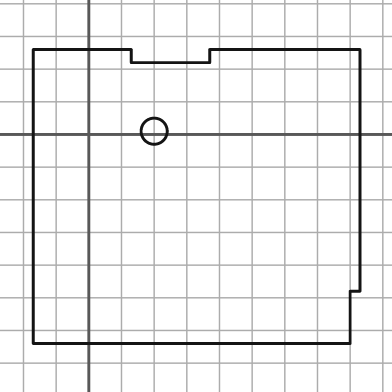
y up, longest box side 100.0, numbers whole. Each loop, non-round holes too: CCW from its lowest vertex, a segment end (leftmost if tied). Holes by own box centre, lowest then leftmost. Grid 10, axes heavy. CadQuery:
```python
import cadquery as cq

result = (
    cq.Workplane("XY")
    .moveTo(-17.0, -64.0)
    .lineTo(80.0, -64.0)
    .lineTo(80.0, -48.0)
    .lineTo(83.0, -48.0)
    .lineTo(83.0, 26.0)
    .lineTo(37.0, 26.0)
    .lineTo(37.0, 22.0)
    .lineTo(13.0, 22.0)
    .lineTo(13.0, 26.0)
    .lineTo(-17.0, 26.0)
    .close()
    .moveTo(20.0, 1.0)
    .circle(4.0)
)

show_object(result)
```